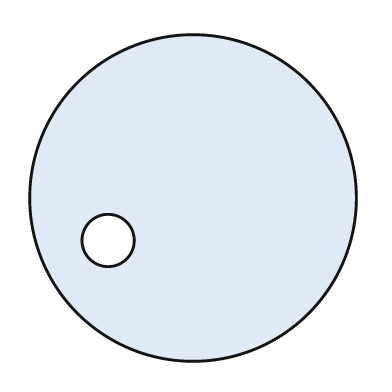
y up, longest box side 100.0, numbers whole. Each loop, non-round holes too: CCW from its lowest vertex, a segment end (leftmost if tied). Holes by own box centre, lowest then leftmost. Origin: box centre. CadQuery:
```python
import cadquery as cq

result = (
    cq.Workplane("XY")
    .moveTo(0.0, 0.0)
    .circle(50.0)
    .moveTo(-26.0, -13.0)
    .circle(8.0)
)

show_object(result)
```